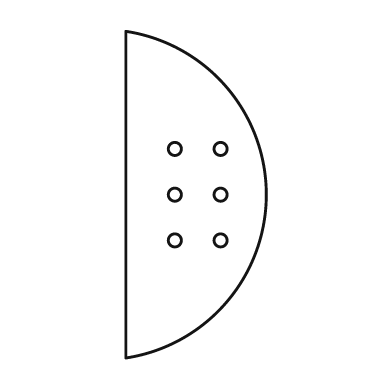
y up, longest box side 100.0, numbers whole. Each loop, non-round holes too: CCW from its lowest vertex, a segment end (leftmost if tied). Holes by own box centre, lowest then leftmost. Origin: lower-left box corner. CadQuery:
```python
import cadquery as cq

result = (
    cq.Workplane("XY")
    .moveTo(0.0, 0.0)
    .threePointArc((43.0, 50.0), (0.0, 100.0))
    .close()
    .moveTo(15.0, 36.0)
    .circle(2.0)
    .moveTo(29.0, 36.0)
    .circle(2.0)
    .moveTo(15.0, 50.0)
    .circle(2.0)
    .moveTo(29.0, 50.0)
    .circle(2.0)
    .moveTo(15.0, 64.0)
    .circle(2.0)
    .moveTo(29.0, 64.0)
    .circle(2.0)
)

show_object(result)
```